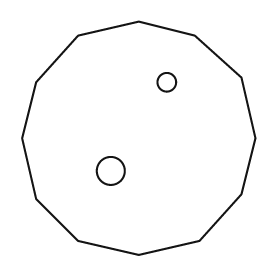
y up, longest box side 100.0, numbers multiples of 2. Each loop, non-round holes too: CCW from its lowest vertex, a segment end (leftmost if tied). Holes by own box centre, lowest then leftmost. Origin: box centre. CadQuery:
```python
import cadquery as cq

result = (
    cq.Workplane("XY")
    .moveTo(0.0, -50.0)
    .lineTo(26.0, -44.0)
    .lineTo(44.0, -24.0)
    .lineTo(50.0, 0.0)
    .lineTo(44.0, 26.0)
    .lineTo(24.0, 44.0)
    .lineTo(0.0, 50.0)
    .lineTo(-26.0, 44.0)
    .lineTo(-44.0, 24.0)
    .lineTo(-50.0, 0.0)
    .lineTo(-44.0, -26.0)
    .lineTo(-26.0, -44.0)
    .close()
    .moveTo(-12.0, -14.0)
    .circle(6.0)
    .moveTo(12.0, 24.0)
    .circle(4.0)
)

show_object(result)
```